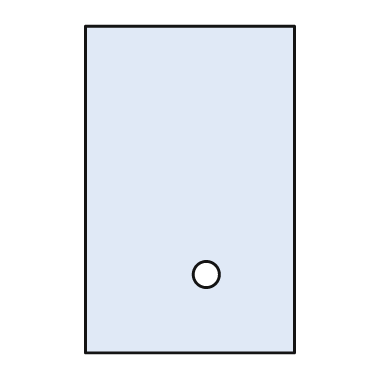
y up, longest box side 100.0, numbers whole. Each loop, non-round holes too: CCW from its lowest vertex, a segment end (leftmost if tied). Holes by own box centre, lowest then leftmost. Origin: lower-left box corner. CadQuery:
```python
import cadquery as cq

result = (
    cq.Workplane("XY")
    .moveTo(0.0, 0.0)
    .lineTo(64.0, 0.0)
    .lineTo(64.0, 100.0)
    .lineTo(0.0, 100.0)
    .close()
    .moveTo(37.0, 24.0)
    .circle(4.0)
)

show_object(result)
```